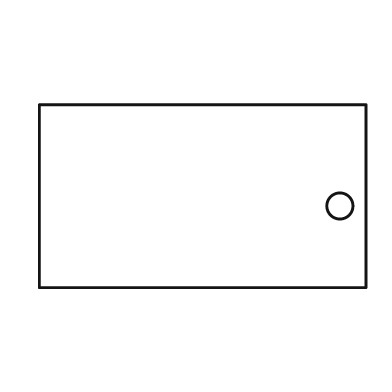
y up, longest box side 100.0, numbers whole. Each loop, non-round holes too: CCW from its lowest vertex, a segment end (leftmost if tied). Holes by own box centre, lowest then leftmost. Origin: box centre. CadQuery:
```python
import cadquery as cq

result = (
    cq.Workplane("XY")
    .moveTo(-50.0, -28.0)
    .lineTo(50.0, -28.0)
    .lineTo(50.0, 28.0)
    .lineTo(-50.0, 28.0)
    .close()
    .moveTo(42.0, -3.0)
    .circle(4.0)
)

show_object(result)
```